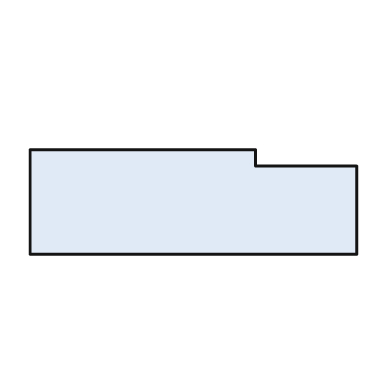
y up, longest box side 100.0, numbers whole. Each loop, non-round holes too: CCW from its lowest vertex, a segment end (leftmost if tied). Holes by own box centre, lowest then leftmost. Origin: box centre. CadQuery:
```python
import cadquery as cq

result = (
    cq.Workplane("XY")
    .moveTo(-50.0, -16.0)
    .lineTo(50.0, -16.0)
    .lineTo(50.0, 11.0)
    .lineTo(19.0, 11.0)
    .lineTo(19.0, 16.0)
    .lineTo(-50.0, 16.0)
    .close()
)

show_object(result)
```